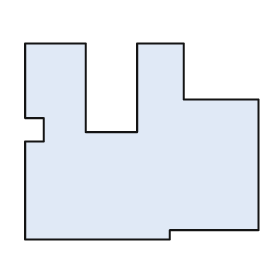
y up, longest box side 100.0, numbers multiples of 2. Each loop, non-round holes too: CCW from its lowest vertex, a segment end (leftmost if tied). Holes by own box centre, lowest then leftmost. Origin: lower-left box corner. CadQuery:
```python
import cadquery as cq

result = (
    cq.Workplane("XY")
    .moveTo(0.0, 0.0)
    .lineTo(62.0, 0.0)
    .lineTo(62.0, 4.0)
    .lineTo(100.0, 4.0)
    .lineTo(100.0, 60.0)
    .lineTo(68.0, 60.0)
    .lineTo(68.0, 84.0)
    .lineTo(48.0, 84.0)
    .lineTo(48.0, 46.0)
    .lineTo(26.0, 46.0)
    .lineTo(26.0, 84.0)
    .lineTo(0.0, 84.0)
    .lineTo(0.0, 52.0)
    .lineTo(8.0, 52.0)
    .lineTo(8.0, 42.0)
    .lineTo(0.0, 42.0)
    .close()
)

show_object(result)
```